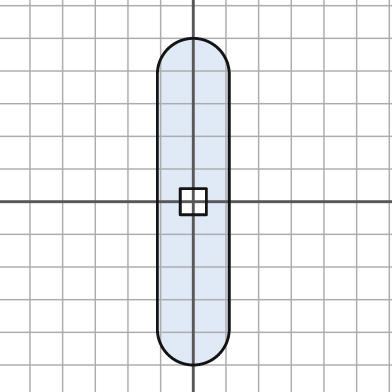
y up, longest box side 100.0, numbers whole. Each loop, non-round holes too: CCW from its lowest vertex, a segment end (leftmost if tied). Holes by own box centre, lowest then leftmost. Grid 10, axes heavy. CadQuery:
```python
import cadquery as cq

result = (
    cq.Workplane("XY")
    .moveTo(-11.0, -39.0)
    .threePointArc((0.0, -50.0), (11.0, -39.0))
    .lineTo(11.0, 39.0)
    .threePointArc((0.0, 50.0), (-11.0, 39.0))
    .close()
    .moveTo(-4.0, -4.0)
    .lineTo(4.0, -4.0)
    .lineTo(4.0, 4.0)
    .lineTo(-4.0, 4.0)
    .close()
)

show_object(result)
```